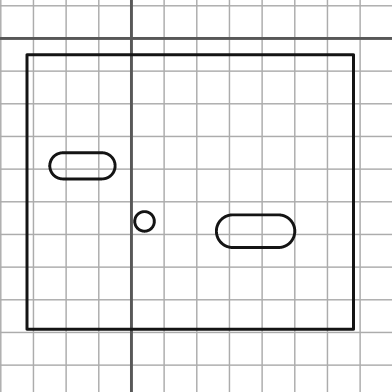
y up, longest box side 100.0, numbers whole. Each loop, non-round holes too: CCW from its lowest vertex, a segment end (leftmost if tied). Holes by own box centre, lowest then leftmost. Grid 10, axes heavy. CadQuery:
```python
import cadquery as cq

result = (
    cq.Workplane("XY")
    .moveTo(-32.0, -89.0)
    .lineTo(68.0, -89.0)
    .lineTo(68.0, -5.0)
    .lineTo(-32.0, -5.0)
    .close()
    .moveTo(31.0, -64.0)
    .lineTo(45.0, -64.0)
    .threePointArc((50.0, -59.0), (45.0, -54.0))
    .lineTo(31.0, -54.0)
    .threePointArc((26.0, -59.0), (31.0, -64.0))
    .close()
    .moveTo(4.0, -56.0)
    .circle(3.0)
    .moveTo(-21.0, -43.0)
    .lineTo(-9.0, -43.0)
    .threePointArc((-5.0, -39.0), (-9.0, -35.0))
    .lineTo(-21.0, -35.0)
    .threePointArc((-25.0, -39.0), (-21.0, -43.0))
    .close()
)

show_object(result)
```